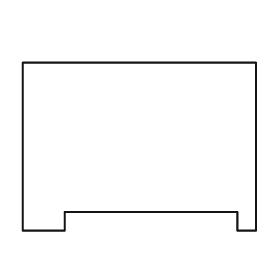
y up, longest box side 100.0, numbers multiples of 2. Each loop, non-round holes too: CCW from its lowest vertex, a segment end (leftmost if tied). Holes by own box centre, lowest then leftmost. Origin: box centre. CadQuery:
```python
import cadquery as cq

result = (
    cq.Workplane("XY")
    .moveTo(-50.0, -36.0)
    .lineTo(-32.0, -36.0)
    .lineTo(-32.0, -28.0)
    .lineTo(42.0, -28.0)
    .lineTo(42.0, -36.0)
    .lineTo(50.0, -36.0)
    .lineTo(50.0, 36.0)
    .lineTo(-50.0, 36.0)
    .close()
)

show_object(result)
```